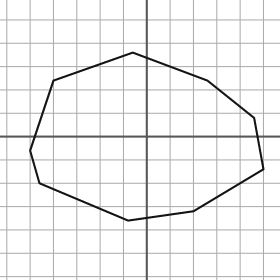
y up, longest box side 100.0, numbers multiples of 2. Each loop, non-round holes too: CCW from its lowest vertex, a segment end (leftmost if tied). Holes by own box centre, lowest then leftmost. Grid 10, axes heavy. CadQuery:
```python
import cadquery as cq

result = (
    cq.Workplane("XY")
    .moveTo(-8.0, -36.0)
    .lineTo(20.0, -32.0)
    .lineTo(50.0, -14.0)
    .lineTo(46.0, 8.0)
    .lineTo(26.0, 24.0)
    .lineTo(-6.0, 36.0)
    .lineTo(-40.0, 24.0)
    .lineTo(-50.0, -6.0)
    .lineTo(-46.0, -20.0)
    .close()
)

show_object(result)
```